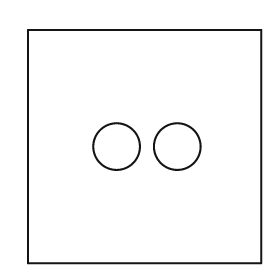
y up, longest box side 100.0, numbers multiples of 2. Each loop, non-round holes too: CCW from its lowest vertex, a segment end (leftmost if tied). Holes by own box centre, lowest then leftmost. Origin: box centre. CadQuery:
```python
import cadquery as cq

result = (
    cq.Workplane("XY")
    .moveTo(-50.0, -50.0)
    .lineTo(50.0, -50.0)
    .lineTo(50.0, 50.0)
    .lineTo(-50.0, 50.0)
    .close()
    .moveTo(-12.0, 0.0)
    .circle(10.0)
    .moveTo(14.0, 0.0)
    .circle(10.0)
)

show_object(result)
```